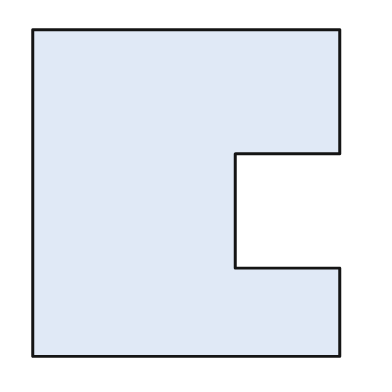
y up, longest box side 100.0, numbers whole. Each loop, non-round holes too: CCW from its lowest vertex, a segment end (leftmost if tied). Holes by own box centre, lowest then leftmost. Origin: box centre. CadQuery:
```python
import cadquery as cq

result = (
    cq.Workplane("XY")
    .moveTo(-47.0, -50.0)
    .lineTo(47.0, -50.0)
    .lineTo(47.0, -23.0)
    .lineTo(15.0, -23.0)
    .lineTo(15.0, 12.0)
    .lineTo(47.0, 12.0)
    .lineTo(47.0, 50.0)
    .lineTo(-47.0, 50.0)
    .close()
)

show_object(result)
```